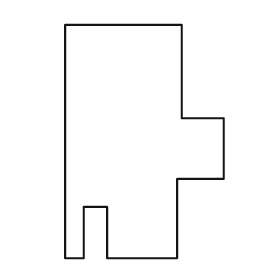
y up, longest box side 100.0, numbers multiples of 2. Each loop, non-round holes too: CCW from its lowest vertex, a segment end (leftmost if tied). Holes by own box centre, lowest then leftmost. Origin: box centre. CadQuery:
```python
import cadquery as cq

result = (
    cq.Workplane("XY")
    .moveTo(-34.0, -50.0)
    .lineTo(-26.0, -50.0)
    .lineTo(-26.0, -28.0)
    .lineTo(-16.0, -28.0)
    .lineTo(-16.0, -50.0)
    .lineTo(14.0, -50.0)
    .lineTo(14.0, -16.0)
    .lineTo(34.0, -16.0)
    .lineTo(34.0, 10.0)
    .lineTo(16.0, 10.0)
    .lineTo(16.0, 50.0)
    .lineTo(-34.0, 50.0)
    .close()
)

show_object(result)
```